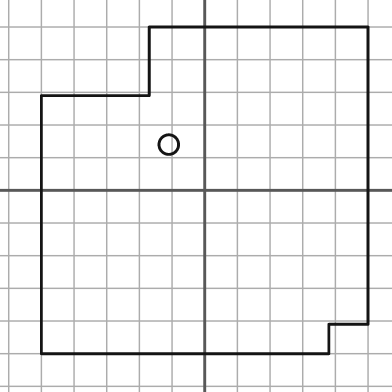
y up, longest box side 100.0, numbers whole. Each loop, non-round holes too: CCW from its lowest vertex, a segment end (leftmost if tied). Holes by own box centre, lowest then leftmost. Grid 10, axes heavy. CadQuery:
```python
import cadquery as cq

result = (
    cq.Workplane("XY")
    .moveTo(-50.0, -50.0)
    .lineTo(38.0, -50.0)
    .lineTo(38.0, -41.0)
    .lineTo(50.0, -41.0)
    .lineTo(50.0, 50.0)
    .lineTo(-17.0, 50.0)
    .lineTo(-17.0, 29.0)
    .lineTo(-50.0, 29.0)
    .close()
    .moveTo(-11.0, 14.0)
    .circle(3.0)
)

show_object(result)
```